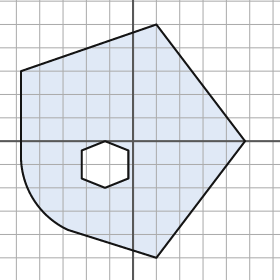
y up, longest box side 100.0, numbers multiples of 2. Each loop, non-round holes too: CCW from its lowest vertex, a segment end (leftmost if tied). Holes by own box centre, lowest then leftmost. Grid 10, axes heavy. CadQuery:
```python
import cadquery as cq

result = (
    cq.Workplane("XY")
    .moveTo(10.0, -50.0)
    .lineTo(48.0, 0.0)
    .lineTo(10.0, 50.0)
    .lineTo(-48.0, 30.0)
    .lineTo(-48.0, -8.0)
    .threePointArc((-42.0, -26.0), (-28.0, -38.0))
    .close()
    .moveTo(-12.0, -20.0)
    .lineTo(-2.0, -16.0)
    .lineTo(-2.0, -4.0)
    .lineTo(-12.0, 0.0)
    .lineTo(-22.0, -4.0)
    .lineTo(-22.0, -16.0)
    .close()
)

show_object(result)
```